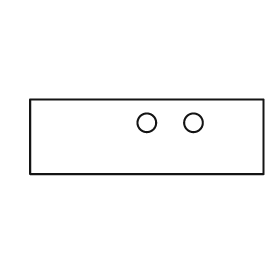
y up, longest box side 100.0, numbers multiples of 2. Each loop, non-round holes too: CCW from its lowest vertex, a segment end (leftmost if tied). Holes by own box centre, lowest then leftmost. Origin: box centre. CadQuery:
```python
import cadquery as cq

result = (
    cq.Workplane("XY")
    .moveTo(-50.0, -16.0)
    .lineTo(50.0, -16.0)
    .lineTo(50.0, 16.0)
    .lineTo(-50.0, 16.0)
    .close()
    .moveTo(0.0, 6.0)
    .circle(4.0)
    .moveTo(20.0, 6.0)
    .circle(4.0)
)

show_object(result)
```